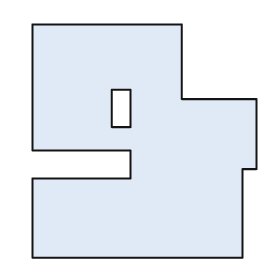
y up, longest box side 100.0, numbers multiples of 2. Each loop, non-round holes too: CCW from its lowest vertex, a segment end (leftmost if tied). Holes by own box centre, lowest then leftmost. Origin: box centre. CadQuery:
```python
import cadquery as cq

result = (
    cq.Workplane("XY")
    .moveTo(-48.0, -50.0)
    .lineTo(42.0, -50.0)
    .lineTo(42.0, -12.0)
    .lineTo(48.0, -12.0)
    .lineTo(48.0, 18.0)
    .lineTo(16.0, 18.0)
    .lineTo(16.0, 50.0)
    .lineTo(-48.0, 50.0)
    .lineTo(-48.0, -4.0)
    .lineTo(-6.0, -4.0)
    .lineTo(-6.0, -16.0)
    .lineTo(-48.0, -16.0)
    .close()
    .moveTo(-14.0, 6.0)
    .lineTo(-6.0, 6.0)
    .lineTo(-6.0, 22.0)
    .lineTo(-14.0, 22.0)
    .close()
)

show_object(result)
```